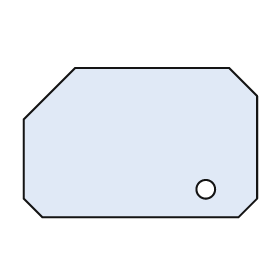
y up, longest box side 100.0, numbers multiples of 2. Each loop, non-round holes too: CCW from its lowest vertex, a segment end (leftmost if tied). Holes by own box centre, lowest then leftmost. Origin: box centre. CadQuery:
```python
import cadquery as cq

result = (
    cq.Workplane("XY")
    .moveTo(-42.0, -32.0)
    .lineTo(42.0, -32.0)
    .lineTo(50.0, -24.0)
    .lineTo(50.0, 20.0)
    .lineTo(38.0, 32.0)
    .lineTo(-28.0, 32.0)
    .lineTo(-50.0, 10.0)
    .lineTo(-50.0, -24.0)
    .close()
    .moveTo(28.0, -20.0)
    .circle(4.0)
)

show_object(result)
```